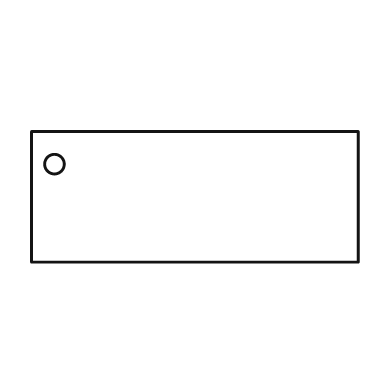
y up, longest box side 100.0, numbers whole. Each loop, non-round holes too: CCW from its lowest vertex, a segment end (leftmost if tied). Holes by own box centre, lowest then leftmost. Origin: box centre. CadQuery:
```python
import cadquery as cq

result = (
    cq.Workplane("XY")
    .moveTo(-50.0, -20.0)
    .lineTo(50.0, -20.0)
    .lineTo(50.0, 20.0)
    .lineTo(-50.0, 20.0)
    .close()
    .moveTo(-43.0, 10.0)
    .circle(3.0)
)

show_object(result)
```